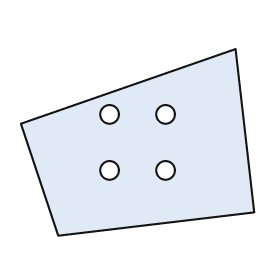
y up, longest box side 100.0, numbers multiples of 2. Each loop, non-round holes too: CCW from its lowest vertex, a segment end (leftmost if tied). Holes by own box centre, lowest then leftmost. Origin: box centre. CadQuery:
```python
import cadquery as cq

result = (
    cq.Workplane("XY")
    .moveTo(-34.0, -40.0)
    .lineTo(50.0, -30.0)
    .lineTo(42.0, 40.0)
    .lineTo(-50.0, 8.0)
    .close()
    .moveTo(-12.0, -12.0)
    .circle(4.0)
    .moveTo(12.0, -12.0)
    .circle(4.0)
    .moveTo(-12.0, 12.0)
    .circle(4.0)
    .moveTo(12.0, 12.0)
    .circle(4.0)
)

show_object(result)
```